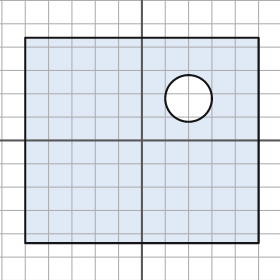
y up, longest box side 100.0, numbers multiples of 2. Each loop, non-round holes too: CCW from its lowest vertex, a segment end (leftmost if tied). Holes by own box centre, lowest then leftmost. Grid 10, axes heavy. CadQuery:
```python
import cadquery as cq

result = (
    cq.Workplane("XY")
    .moveTo(-50.0, -44.0)
    .lineTo(50.0, -44.0)
    .lineTo(50.0, 44.0)
    .lineTo(-50.0, 44.0)
    .close()
    .moveTo(20.0, 18.0)
    .circle(10.0)
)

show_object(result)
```